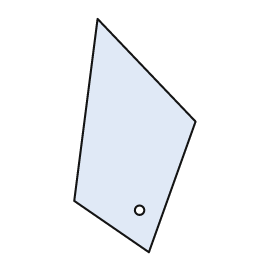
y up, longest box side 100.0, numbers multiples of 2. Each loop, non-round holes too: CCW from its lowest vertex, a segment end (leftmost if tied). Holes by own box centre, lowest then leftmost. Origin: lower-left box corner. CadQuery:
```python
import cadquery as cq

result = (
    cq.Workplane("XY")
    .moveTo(32.0, 0.0)
    .lineTo(52.0, 56.0)
    .lineTo(10.0, 100.0)
    .lineTo(0.0, 22.0)
    .close()
    .moveTo(28.0, 18.0)
    .circle(2.0)
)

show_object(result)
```